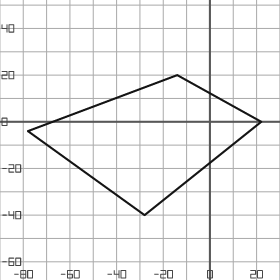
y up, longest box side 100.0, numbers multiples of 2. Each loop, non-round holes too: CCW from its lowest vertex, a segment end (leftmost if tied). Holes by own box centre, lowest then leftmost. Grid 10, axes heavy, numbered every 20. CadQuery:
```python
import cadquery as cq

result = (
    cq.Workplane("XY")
    .moveTo(-28.0, -40.0)
    .lineTo(22.0, 0.0)
    .lineTo(-14.0, 20.0)
    .lineTo(-78.0, -4.0)
    .close()
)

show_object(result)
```